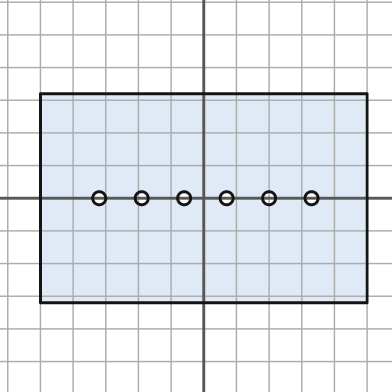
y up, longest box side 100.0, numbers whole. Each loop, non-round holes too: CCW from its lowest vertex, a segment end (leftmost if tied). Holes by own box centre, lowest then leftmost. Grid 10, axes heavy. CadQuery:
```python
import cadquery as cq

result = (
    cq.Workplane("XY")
    .moveTo(-50.0, -32.0)
    .lineTo(50.0, -32.0)
    .lineTo(50.0, 32.0)
    .lineTo(-50.0, 32.0)
    .close()
    .moveTo(-32.0, 0.0)
    .circle(2.0)
    .moveTo(-19.0, 0.0)
    .circle(2.0)
    .moveTo(-6.0, 0.0)
    .circle(2.0)
    .moveTo(7.0, 0.0)
    .circle(2.0)
    .moveTo(20.0, 0.0)
    .circle(2.0)
    .moveTo(33.0, 0.0)
    .circle(2.0)
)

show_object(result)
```